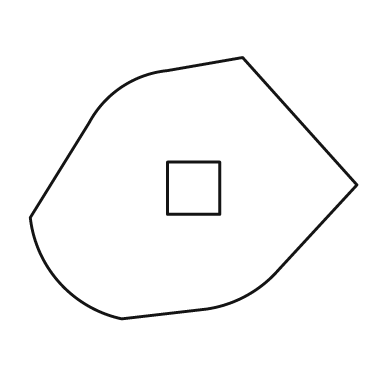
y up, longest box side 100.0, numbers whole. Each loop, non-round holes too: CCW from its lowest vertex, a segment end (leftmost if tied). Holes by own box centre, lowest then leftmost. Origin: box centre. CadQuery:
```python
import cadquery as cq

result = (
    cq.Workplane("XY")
    .moveTo(-22.0, -40.0)
    .lineTo(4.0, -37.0)
    .threePointArc((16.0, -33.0), (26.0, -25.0))
    .lineTo(50.0, 1.0)
    .lineTo(15.0, 40.0)
    .lineTo(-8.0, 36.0)
    .threePointArc((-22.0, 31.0), (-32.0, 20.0))
    .lineTo(-50.0, -9.0)
    .threePointArc((-41.0, -29.0), (-22.0, -40.0))
    .close()
    .moveTo(-8.0, -8.0)
    .lineTo(8.0, -8.0)
    .lineTo(8.0, 8.0)
    .lineTo(-8.0, 8.0)
    .close()
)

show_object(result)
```